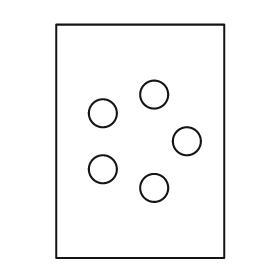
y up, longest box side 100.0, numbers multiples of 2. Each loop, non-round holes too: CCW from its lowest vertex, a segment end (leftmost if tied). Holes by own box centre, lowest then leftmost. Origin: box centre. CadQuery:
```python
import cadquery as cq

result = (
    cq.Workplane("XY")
    .moveTo(-36.0, -50.0)
    .lineTo(36.0, -50.0)
    .lineTo(36.0, 50.0)
    .lineTo(-36.0, 50.0)
    .close()
    .moveTo(6.0, -20.0)
    .circle(6.0)
    .moveTo(-16.0, -12.0)
    .circle(6.0)
    .moveTo(20.0, 0.0)
    .circle(6.0)
    .moveTo(-16.0, 12.0)
    .circle(6.0)
    .moveTo(6.0, 20.0)
    .circle(6.0)
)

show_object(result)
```